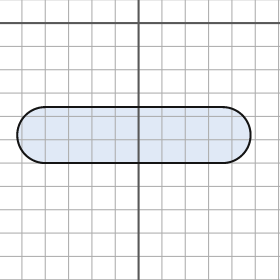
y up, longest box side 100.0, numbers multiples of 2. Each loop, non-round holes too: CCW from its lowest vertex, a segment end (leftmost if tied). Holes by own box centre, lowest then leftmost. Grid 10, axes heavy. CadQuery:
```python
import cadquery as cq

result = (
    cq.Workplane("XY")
    .moveTo(-40.0, -60.0)
    .lineTo(36.0, -60.0)
    .threePointArc((48.0, -48.0), (36.0, -36.0))
    .lineTo(-40.0, -36.0)
    .threePointArc((-52.0, -48.0), (-40.0, -60.0))
    .close()
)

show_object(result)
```